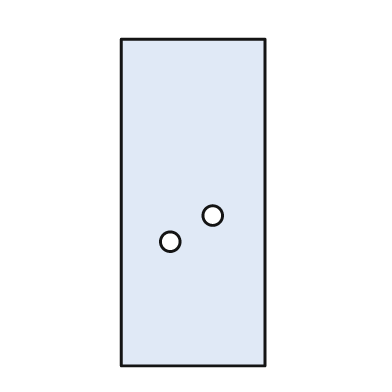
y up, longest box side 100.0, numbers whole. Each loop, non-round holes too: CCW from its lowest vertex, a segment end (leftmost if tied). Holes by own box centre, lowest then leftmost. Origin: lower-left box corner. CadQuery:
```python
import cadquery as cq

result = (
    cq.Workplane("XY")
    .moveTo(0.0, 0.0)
    .lineTo(44.0, 0.0)
    .lineTo(44.0, 100.0)
    .lineTo(0.0, 100.0)
    .close()
    .moveTo(15.0, 38.0)
    .circle(3.0)
    .moveTo(28.0, 46.0)
    .circle(3.0)
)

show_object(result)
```